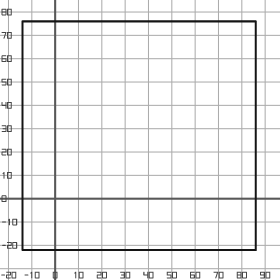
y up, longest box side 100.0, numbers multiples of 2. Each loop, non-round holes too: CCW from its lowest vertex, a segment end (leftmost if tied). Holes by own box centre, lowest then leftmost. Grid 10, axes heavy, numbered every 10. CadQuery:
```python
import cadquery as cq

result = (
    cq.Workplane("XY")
    .moveTo(-14.0, -22.0)
    .lineTo(86.0, -22.0)
    .lineTo(86.0, 76.0)
    .lineTo(-14.0, 76.0)
    .close()
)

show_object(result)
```